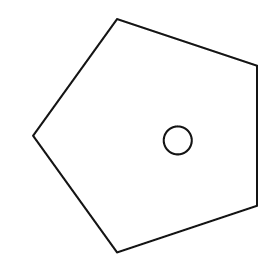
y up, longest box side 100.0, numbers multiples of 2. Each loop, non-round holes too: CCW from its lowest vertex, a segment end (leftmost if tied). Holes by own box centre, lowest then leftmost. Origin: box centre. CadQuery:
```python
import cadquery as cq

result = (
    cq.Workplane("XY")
    .moveTo(-12.0, -50.0)
    .lineTo(48.0, -30.0)
    .lineTo(48.0, 30.0)
    .lineTo(-12.0, 50.0)
    .lineTo(-48.0, 0.0)
    .close()
    .moveTo(14.0, -2.0)
    .circle(6.0)
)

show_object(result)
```